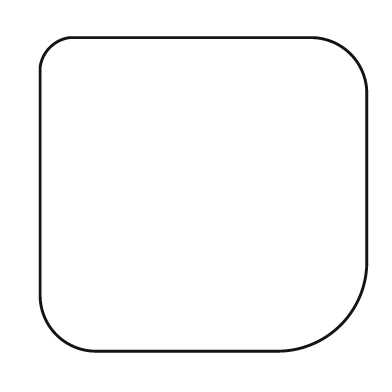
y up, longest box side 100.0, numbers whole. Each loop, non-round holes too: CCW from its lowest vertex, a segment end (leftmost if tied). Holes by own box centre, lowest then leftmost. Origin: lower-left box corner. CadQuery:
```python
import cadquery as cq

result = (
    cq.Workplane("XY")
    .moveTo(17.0, 0.0)
    .lineTo(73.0, 0.0)
    .threePointArc((92.0, 8.0), (100.0, 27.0))
    .lineTo(100.0, 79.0)
    .threePointArc((95.0, 91.0), (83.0, 96.0))
    .lineTo(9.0, 96.0)
    .threePointArc((3.0, 93.0), (0.0, 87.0))
    .lineTo(0.0, 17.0)
    .threePointArc((5.0, 5.0), (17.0, 0.0))
    .close()
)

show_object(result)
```